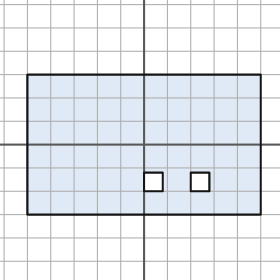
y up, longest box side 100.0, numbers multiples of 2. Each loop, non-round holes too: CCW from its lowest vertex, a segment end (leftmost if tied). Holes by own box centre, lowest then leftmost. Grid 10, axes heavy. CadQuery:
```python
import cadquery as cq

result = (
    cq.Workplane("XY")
    .moveTo(-50.0, -30.0)
    .lineTo(50.0, -30.0)
    .lineTo(50.0, 30.0)
    .lineTo(-50.0, 30.0)
    .close()
    .moveTo(0.0, -20.0)
    .lineTo(8.0, -20.0)
    .lineTo(8.0, -12.0)
    .lineTo(0.0, -12.0)
    .close()
    .moveTo(20.0, -20.0)
    .lineTo(28.0, -20.0)
    .lineTo(28.0, -12.0)
    .lineTo(20.0, -12.0)
    .close()
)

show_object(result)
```